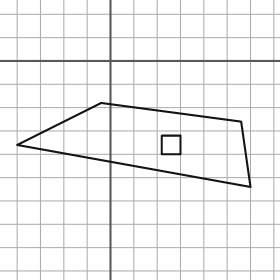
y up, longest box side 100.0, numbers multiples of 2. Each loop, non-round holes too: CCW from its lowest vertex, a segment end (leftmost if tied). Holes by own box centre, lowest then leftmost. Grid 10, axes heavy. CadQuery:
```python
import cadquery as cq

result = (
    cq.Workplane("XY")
    .moveTo(60.0, -54.0)
    .lineTo(56.0, -26.0)
    .lineTo(-4.0, -18.0)
    .lineTo(-40.0, -36.0)
    .close()
    .moveTo(22.0, -40.0)
    .lineTo(30.0, -40.0)
    .lineTo(30.0, -32.0)
    .lineTo(22.0, -32.0)
    .close()
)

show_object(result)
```